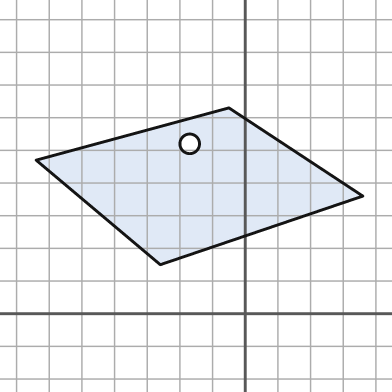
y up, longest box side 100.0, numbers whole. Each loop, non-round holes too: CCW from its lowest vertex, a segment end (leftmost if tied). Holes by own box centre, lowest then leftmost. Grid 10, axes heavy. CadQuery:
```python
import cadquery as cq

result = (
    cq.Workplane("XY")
    .moveTo(-26.0, 15.0)
    .lineTo(36.0, 36.0)
    .lineTo(-5.0, 63.0)
    .lineTo(-64.0, 47.0)
    .close()
    .moveTo(-17.0, 52.0)
    .circle(3.0)
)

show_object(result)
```